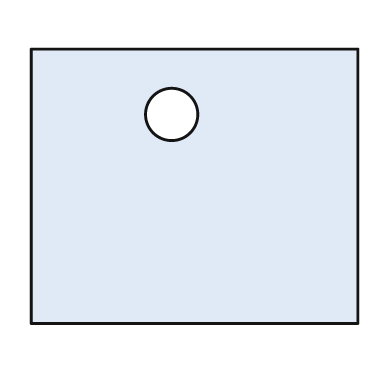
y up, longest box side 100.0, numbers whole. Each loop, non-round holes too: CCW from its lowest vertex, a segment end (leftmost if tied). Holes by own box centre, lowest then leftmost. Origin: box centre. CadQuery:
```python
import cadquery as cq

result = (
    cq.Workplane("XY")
    .moveTo(-50.0, -42.0)
    .lineTo(50.0, -42.0)
    .lineTo(50.0, 42.0)
    .lineTo(-50.0, 42.0)
    .close()
    .moveTo(-7.0, 22.0)
    .circle(8.0)
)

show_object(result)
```